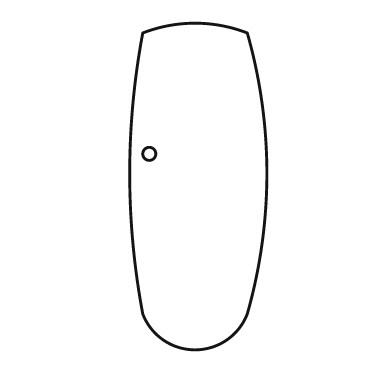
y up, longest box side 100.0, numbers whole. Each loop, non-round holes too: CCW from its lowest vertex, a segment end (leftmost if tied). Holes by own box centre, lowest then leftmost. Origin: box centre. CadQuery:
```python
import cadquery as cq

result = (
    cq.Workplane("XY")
    .moveTo(-17.0, -39.0)
    .threePointArc((-1.0, -50.0), (15.0, -39.0))
    .threePointArc((21.0, 4.0), (15.0, 47.0))
    .threePointArc((-1.0, 50.0), (-17.0, 47.0))
    .threePointArc((-21.0, 4.0), (-17.0, -39.0))
    .close()
    .moveTo(-15.0, 10.0)
    .circle(2.0)
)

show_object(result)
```